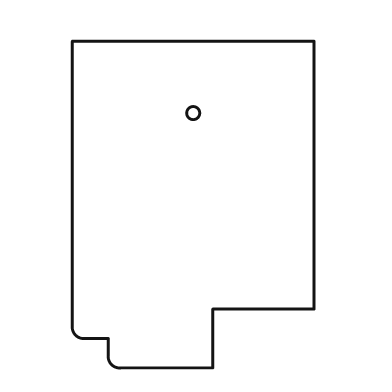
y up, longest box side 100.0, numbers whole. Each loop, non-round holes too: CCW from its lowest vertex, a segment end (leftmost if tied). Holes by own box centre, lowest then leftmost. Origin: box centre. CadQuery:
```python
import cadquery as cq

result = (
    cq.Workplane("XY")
    .moveTo(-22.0, -50.0)
    .lineTo(6.0, -50.0)
    .lineTo(6.0, -32.0)
    .lineTo(37.0, -32.0)
    .lineTo(37.0, 50.0)
    .lineTo(-37.0, 50.0)
    .lineTo(-37.0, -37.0)
    .threePointArc((-36.0, -40.0), (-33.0, -41.0))
    .lineTo(-26.0, -41.0)
    .lineTo(-26.0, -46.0)
    .threePointArc((-25.0, -49.0), (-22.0, -50.0))
    .close()
    .moveTo(0.0, 28.0)
    .circle(2.0)
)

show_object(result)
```